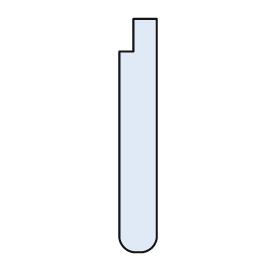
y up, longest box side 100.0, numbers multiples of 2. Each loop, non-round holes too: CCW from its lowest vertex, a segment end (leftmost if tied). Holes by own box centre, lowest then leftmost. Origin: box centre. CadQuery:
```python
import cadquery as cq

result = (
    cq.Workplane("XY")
    .moveTo(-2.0, -50.0)
    .lineTo(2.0, -50.0)
    .threePointArc((6.0, -48.0), (8.0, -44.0))
    .lineTo(8.0, 50.0)
    .lineTo(-2.0, 50.0)
    .lineTo(-2.0, 36.0)
    .lineTo(-8.0, 36.0)
    .lineTo(-8.0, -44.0)
    .threePointArc((-6.0, -48.0), (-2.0, -50.0))
    .close()
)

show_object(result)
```